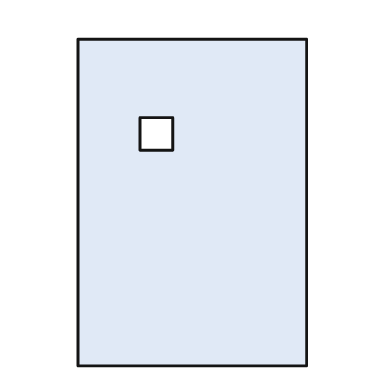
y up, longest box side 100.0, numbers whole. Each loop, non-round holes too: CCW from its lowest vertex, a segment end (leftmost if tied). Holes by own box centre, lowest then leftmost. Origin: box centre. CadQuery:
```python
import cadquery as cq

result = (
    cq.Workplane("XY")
    .moveTo(-35.0, -50.0)
    .lineTo(35.0, -50.0)
    .lineTo(35.0, 50.0)
    .lineTo(-35.0, 50.0)
    .close()
    .moveTo(-16.0, 16.0)
    .lineTo(-6.0, 16.0)
    .lineTo(-6.0, 26.0)
    .lineTo(-16.0, 26.0)
    .close()
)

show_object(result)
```